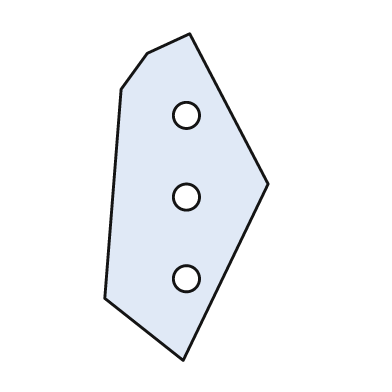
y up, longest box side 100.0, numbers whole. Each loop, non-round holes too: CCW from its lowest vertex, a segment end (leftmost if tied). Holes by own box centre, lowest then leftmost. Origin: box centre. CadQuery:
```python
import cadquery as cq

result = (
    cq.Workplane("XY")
    .moveTo(-1.0, -50.0)
    .lineTo(25.0, 4.0)
    .lineTo(1.0, 50.0)
    .lineTo(-12.0, 44.0)
    .lineTo(-20.0, 33.0)
    .lineTo(-25.0, -31.0)
    .close()
    .moveTo(0.0, -25.0)
    .circle(4.0)
    .moveTo(0.0, 0.0)
    .circle(4.0)
    .moveTo(0.0, 25.0)
    .circle(4.0)
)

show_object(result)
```